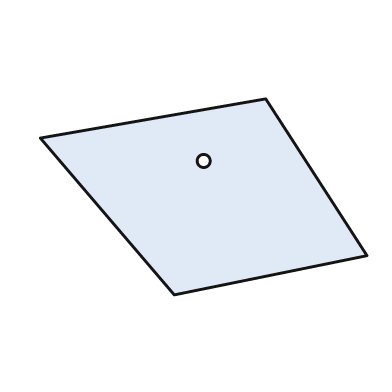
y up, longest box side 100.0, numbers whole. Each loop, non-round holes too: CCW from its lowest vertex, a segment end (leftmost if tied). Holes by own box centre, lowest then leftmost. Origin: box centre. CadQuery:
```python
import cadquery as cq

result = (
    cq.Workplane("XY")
    .moveTo(-9.0, -30.0)
    .lineTo(50.0, -18.0)
    .lineTo(19.0, 30.0)
    .lineTo(-50.0, 18.0)
    .close()
    .moveTo(0.0, 11.0)
    .circle(2.0)
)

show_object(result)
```